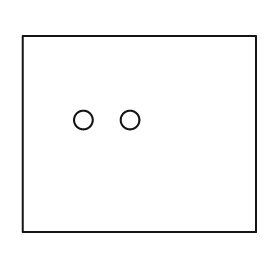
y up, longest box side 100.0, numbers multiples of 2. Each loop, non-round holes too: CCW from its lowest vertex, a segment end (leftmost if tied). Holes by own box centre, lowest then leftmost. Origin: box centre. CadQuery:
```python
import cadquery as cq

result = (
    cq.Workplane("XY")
    .moveTo(-50.0, -42.0)
    .lineTo(50.0, -42.0)
    .lineTo(50.0, 42.0)
    .lineTo(-50.0, 42.0)
    .close()
    .moveTo(-24.0, 6.0)
    .circle(4.0)
    .moveTo(-4.0, 6.0)
    .circle(4.0)
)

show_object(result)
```